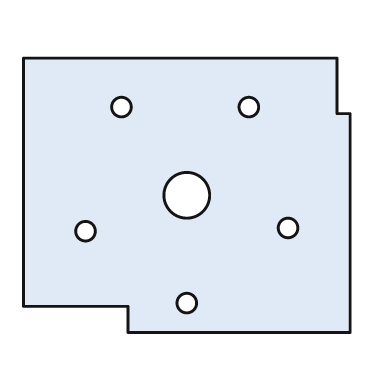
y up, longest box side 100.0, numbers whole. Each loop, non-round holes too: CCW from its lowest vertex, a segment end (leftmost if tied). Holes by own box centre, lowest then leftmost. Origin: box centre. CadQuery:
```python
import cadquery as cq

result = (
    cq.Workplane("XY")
    .moveTo(-18.0, -42.0)
    .lineTo(50.0, -42.0)
    .lineTo(50.0, 25.0)
    .lineTo(46.0, 25.0)
    .lineTo(46.0, 42.0)
    .lineTo(-50.0, 42.0)
    .lineTo(-50.0, -34.0)
    .lineTo(-18.0, -34.0)
    .close()
    .moveTo(0.0, -33.0)
    .circle(3.0)
    .moveTo(-31.0, -11.0)
    .circle(3.0)
    .moveTo(31.0, -10.0)
    .circle(3.0)
    .moveTo(0.0, 0.0)
    .circle(7.0)
    .moveTo(-20.0, 27.0)
    .circle(3.0)
    .moveTo(19.0, 27.0)
    .circle(3.0)
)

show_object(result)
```